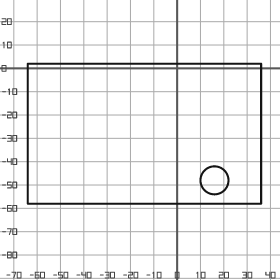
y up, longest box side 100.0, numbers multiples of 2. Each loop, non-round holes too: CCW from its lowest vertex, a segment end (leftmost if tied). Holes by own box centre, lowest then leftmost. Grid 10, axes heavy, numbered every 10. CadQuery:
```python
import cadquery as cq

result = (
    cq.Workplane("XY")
    .moveTo(-64.0, -58.0)
    .lineTo(36.0, -58.0)
    .lineTo(36.0, 2.0)
    .lineTo(-64.0, 2.0)
    .close()
    .moveTo(16.0, -48.0)
    .circle(6.0)
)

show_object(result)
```